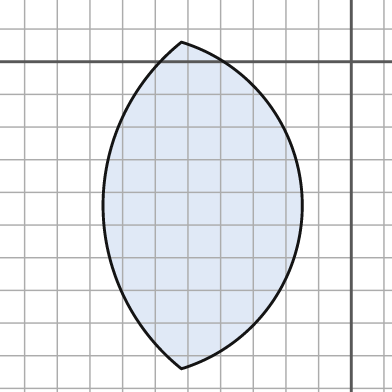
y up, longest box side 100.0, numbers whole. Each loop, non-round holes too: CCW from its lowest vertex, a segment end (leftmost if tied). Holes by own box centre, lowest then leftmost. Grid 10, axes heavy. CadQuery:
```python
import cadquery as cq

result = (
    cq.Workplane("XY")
    .moveTo(-52.0, -94.0)
    .threePointArc((-15.0, -44.0), (-52.0, 6.0))
    .threePointArc((-76.0, -44.0), (-52.0, -94.0))
    .close()
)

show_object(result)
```